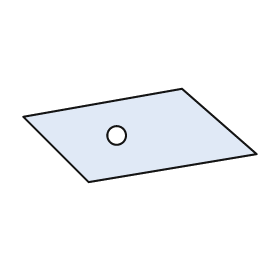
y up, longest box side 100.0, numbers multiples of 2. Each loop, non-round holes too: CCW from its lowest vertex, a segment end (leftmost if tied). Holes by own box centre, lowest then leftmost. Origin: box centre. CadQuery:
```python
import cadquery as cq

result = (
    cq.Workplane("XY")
    .moveTo(-22.0, -20.0)
    .lineTo(50.0, -8.0)
    .lineTo(18.0, 20.0)
    .lineTo(-50.0, 8.0)
    .close()
    .moveTo(-10.0, 0.0)
    .circle(4.0)
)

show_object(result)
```